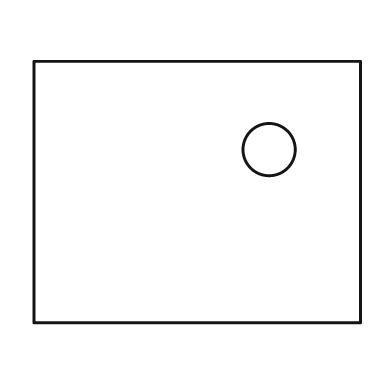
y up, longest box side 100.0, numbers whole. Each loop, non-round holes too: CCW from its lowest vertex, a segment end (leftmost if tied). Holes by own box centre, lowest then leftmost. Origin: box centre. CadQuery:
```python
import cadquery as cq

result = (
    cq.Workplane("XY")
    .moveTo(-50.0, -40.0)
    .lineTo(50.0, -40.0)
    .lineTo(50.0, 40.0)
    .lineTo(-50.0, 40.0)
    .close()
    .moveTo(22.0, 13.0)
    .circle(8.0)
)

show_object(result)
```